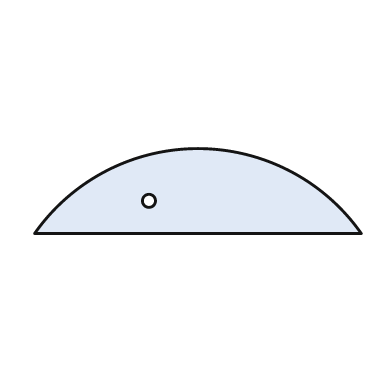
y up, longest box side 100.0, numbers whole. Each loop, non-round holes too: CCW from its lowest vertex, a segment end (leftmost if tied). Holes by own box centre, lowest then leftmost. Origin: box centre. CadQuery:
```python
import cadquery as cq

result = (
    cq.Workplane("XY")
    .moveTo(-50.0, -13.0)
    .lineTo(50.0, -13.0)
    .threePointArc((0.0, 13.0), (-50.0, -13.0))
    .close()
    .moveTo(-15.0, -3.0)
    .circle(2.0)
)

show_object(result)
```